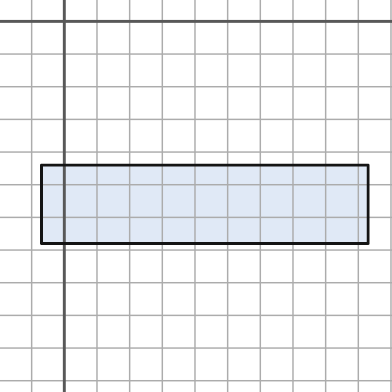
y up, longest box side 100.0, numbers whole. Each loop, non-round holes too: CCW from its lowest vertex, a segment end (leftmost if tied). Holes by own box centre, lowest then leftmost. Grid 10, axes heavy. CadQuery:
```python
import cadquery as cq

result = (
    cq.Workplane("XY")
    .moveTo(-7.0, -68.0)
    .lineTo(93.0, -68.0)
    .lineTo(93.0, -44.0)
    .lineTo(-7.0, -44.0)
    .close()
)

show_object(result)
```